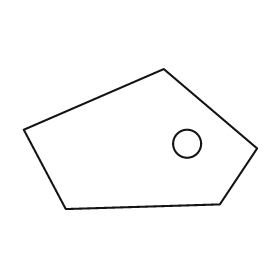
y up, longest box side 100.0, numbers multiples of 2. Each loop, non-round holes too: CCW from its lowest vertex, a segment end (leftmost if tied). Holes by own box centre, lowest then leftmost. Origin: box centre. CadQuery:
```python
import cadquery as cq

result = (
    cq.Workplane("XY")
    .moveTo(-32.0, -30.0)
    .lineTo(34.0, -28.0)
    .lineTo(50.0, -4.0)
    .lineTo(10.0, 30.0)
    .lineTo(-50.0, 4.0)
    .close()
    .moveTo(20.0, -2.0)
    .circle(6.0)
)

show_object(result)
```